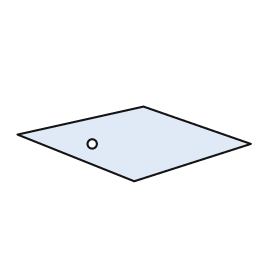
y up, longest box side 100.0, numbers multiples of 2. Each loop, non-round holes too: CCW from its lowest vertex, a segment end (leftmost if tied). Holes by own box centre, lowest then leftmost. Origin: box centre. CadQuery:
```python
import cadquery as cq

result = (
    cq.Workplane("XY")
    .moveTo(0.0, -16.0)
    .lineTo(50.0, 0.0)
    .lineTo(4.0, 16.0)
    .lineTo(-50.0, 4.0)
    .close()
    .moveTo(-18.0, 0.0)
    .circle(2.0)
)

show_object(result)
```